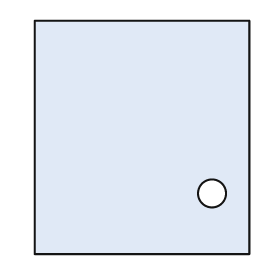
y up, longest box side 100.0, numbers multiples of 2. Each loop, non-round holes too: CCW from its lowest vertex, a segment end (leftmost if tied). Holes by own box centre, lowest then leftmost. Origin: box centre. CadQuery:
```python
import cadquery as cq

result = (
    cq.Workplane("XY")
    .moveTo(-46.0, -50.0)
    .lineTo(46.0, -50.0)
    .lineTo(46.0, 50.0)
    .lineTo(-46.0, 50.0)
    .close()
    .moveTo(30.0, -24.0)
    .circle(6.0)
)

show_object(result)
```